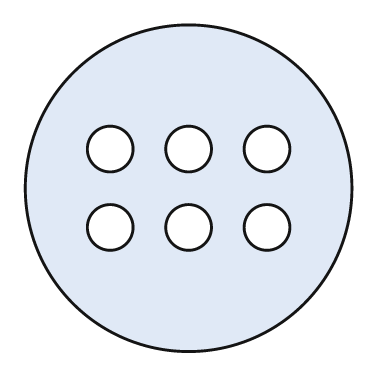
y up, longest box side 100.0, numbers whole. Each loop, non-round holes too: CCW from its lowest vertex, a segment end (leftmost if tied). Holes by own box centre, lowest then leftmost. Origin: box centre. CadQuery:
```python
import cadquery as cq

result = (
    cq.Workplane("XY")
    .moveTo(0.0, 0.0)
    .circle(50.0)
    .moveTo(-24.0, -12.0)
    .circle(7.0)
    .moveTo(0.0, -12.0)
    .circle(7.0)
    .moveTo(24.0, -12.0)
    .circle(7.0)
    .moveTo(-24.0, 12.0)
    .circle(7.0)
    .moveTo(0.0, 12.0)
    .circle(7.0)
    .moveTo(24.0, 12.0)
    .circle(7.0)
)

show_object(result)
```